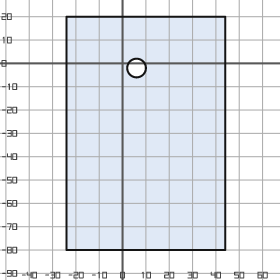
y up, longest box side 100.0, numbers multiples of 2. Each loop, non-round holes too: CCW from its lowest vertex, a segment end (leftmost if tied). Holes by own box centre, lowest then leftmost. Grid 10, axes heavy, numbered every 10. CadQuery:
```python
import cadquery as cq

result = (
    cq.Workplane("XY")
    .moveTo(-24.0, -80.0)
    .lineTo(44.0, -80.0)
    .lineTo(44.0, 20.0)
    .lineTo(-24.0, 20.0)
    .close()
    .moveTo(6.0, -2.0)
    .circle(4.0)
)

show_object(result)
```